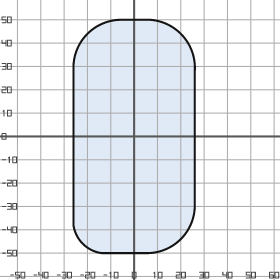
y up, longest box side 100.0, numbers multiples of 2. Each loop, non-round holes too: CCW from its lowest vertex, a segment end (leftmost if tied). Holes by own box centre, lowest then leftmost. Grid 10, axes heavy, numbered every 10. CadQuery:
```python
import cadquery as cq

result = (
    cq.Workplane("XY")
    .moveTo(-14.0, -50.0)
    .lineTo(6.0, -50.0)
    .threePointArc((20.0, -44.0), (26.0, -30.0))
    .lineTo(26.0, 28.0)
    .threePointArc((20.0, 44.0), (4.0, 50.0))
    .lineTo(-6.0, 50.0)
    .threePointArc((-20.0, 44.0), (-26.0, 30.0))
    .lineTo(-26.0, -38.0)
    .threePointArc((-22.0, -46.0), (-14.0, -50.0))
    .close()
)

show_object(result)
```